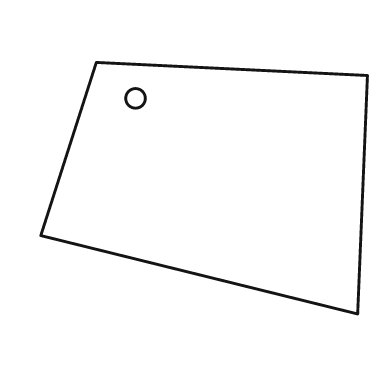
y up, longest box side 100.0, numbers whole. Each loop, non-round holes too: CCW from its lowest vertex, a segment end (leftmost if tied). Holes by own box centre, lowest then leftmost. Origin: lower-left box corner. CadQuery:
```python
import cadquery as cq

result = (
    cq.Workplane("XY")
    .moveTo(97.0, 0.0)
    .lineTo(100.0, 73.0)
    .lineTo(17.0, 77.0)
    .lineTo(0.0, 24.0)
    .close()
    .moveTo(29.0, 66.0)
    .circle(3.0)
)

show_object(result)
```